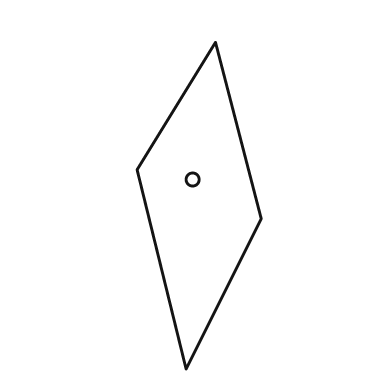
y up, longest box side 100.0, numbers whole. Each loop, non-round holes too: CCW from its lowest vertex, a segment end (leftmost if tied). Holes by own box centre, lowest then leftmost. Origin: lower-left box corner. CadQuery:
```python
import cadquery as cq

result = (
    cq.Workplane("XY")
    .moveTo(15.0, 0.0)
    .lineTo(38.0, 46.0)
    .lineTo(24.0, 100.0)
    .lineTo(0.0, 61.0)
    .close()
    .moveTo(17.0, 58.0)
    .circle(2.0)
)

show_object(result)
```